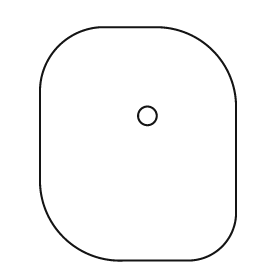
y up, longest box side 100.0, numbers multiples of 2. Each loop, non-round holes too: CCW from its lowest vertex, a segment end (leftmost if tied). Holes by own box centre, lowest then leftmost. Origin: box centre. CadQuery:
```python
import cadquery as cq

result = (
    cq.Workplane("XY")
    .moveTo(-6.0, -50.0)
    .lineTo(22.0, -50.0)
    .threePointArc((36.0, -44.0), (42.0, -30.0))
    .lineTo(42.0, 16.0)
    .threePointArc((32.0, 40.0), (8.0, 50.0))
    .lineTo(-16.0, 50.0)
    .threePointArc((-34.0, 42.0), (-42.0, 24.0))
    .lineTo(-42.0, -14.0)
    .threePointArc((-32.0, -40.0), (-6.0, -50.0))
    .close()
    .moveTo(4.0, 12.0)
    .circle(4.0)
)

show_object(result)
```